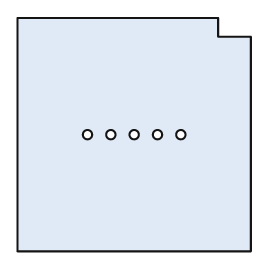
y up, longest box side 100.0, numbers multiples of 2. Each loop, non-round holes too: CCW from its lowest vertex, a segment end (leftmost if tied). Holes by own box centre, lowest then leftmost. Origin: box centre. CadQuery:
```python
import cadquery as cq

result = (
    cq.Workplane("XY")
    .moveTo(-50.0, -50.0)
    .lineTo(50.0, -50.0)
    .lineTo(50.0, 42.0)
    .lineTo(36.0, 42.0)
    .lineTo(36.0, 50.0)
    .lineTo(-50.0, 50.0)
    .close()
    .moveTo(-20.0, 0.0)
    .circle(2.0)
    .moveTo(-10.0, 0.0)
    .circle(2.0)
    .moveTo(0.0, 0.0)
    .circle(2.0)
    .moveTo(10.0, 0.0)
    .circle(2.0)
    .moveTo(20.0, 0.0)
    .circle(2.0)
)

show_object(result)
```